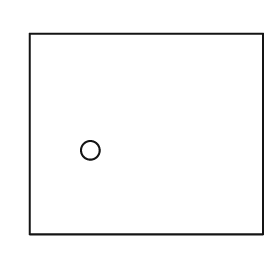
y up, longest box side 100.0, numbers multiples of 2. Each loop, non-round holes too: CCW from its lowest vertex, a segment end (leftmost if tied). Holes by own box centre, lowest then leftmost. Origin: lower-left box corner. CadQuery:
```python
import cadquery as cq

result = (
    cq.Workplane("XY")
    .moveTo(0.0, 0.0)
    .lineTo(100.0, 0.0)
    .lineTo(100.0, 86.0)
    .lineTo(0.0, 86.0)
    .close()
    .moveTo(26.0, 36.0)
    .circle(4.0)
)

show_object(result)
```